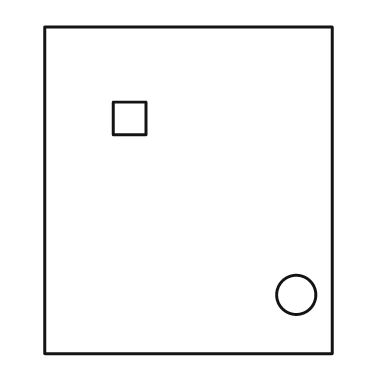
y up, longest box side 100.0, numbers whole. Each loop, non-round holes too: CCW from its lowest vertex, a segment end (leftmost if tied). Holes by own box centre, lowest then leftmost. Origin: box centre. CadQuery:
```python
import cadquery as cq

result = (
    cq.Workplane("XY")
    .moveTo(-44.0, -50.0)
    .lineTo(44.0, -50.0)
    .lineTo(44.0, 50.0)
    .lineTo(-44.0, 50.0)
    .close()
    .moveTo(33.0, -32.0)
    .circle(6.0)
    .moveTo(-23.0, 17.0)
    .lineTo(-13.0, 17.0)
    .lineTo(-13.0, 27.0)
    .lineTo(-23.0, 27.0)
    .close()
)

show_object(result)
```